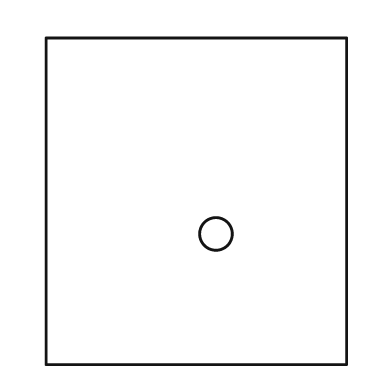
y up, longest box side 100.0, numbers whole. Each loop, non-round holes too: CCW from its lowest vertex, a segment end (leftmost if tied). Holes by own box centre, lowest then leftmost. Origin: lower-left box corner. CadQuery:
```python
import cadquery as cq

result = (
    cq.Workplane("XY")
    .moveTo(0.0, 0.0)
    .lineTo(92.0, 0.0)
    .lineTo(92.0, 100.0)
    .lineTo(0.0, 100.0)
    .close()
    .moveTo(52.0, 40.0)
    .circle(5.0)
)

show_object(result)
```